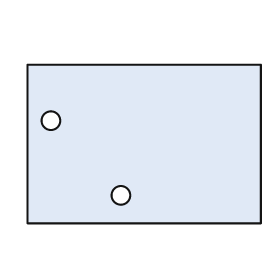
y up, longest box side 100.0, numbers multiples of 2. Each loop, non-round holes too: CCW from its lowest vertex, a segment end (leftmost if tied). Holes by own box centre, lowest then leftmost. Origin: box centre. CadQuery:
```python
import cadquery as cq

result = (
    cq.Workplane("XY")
    .moveTo(-50.0, -34.0)
    .lineTo(50.0, -34.0)
    .lineTo(50.0, 34.0)
    .lineTo(-50.0, 34.0)
    .close()
    .moveTo(-10.0, -22.0)
    .circle(4.0)
    .moveTo(-40.0, 10.0)
    .circle(4.0)
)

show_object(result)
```